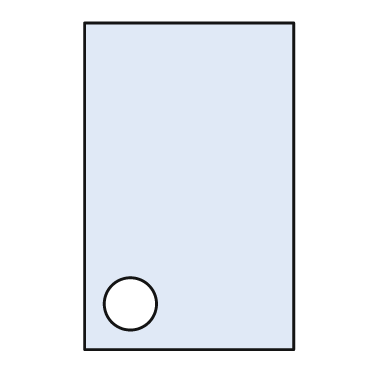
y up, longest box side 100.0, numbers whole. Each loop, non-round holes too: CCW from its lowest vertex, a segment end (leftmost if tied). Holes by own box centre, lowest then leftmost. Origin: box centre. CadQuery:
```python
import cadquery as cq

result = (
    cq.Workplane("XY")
    .moveTo(-32.0, -50.0)
    .lineTo(32.0, -50.0)
    .lineTo(32.0, 50.0)
    .lineTo(-32.0, 50.0)
    .close()
    .moveTo(-18.0, -36.0)
    .circle(8.0)
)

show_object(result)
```